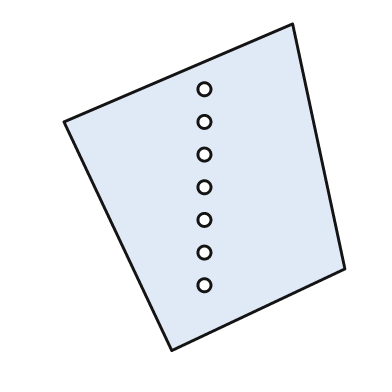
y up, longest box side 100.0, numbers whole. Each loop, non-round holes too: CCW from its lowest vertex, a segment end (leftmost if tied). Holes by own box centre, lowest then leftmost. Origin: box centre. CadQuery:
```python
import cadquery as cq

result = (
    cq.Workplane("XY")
    .moveTo(-10.0, -50.0)
    .lineTo(43.0, -25.0)
    .lineTo(27.0, 50.0)
    .lineTo(-43.0, 20.0)
    .close()
    .moveTo(0.0, -30.0)
    .circle(2.0)
    .moveTo(0.0, -20.0)
    .circle(2.0)
    .moveTo(0.0, -10.0)
    .circle(2.0)
    .moveTo(0.0, 0.0)
    .circle(2.0)
    .moveTo(0.0, 10.0)
    .circle(2.0)
    .moveTo(0.0, 20.0)
    .circle(2.0)
    .moveTo(0.0, 30.0)
    .circle(2.0)
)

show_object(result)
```